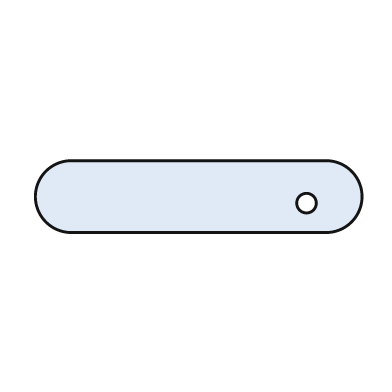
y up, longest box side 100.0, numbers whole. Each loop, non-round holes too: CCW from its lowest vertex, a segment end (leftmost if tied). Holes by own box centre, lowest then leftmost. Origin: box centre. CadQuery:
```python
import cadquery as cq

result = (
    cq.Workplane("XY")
    .moveTo(-39.0, -11.0)
    .lineTo(39.0, -11.0)
    .threePointArc((50.0, 0.0), (39.0, 11.0))
    .lineTo(-39.0, 11.0)
    .threePointArc((-50.0, 0.0), (-39.0, -11.0))
    .close()
    .moveTo(33.0, -2.0)
    .circle(3.0)
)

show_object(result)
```